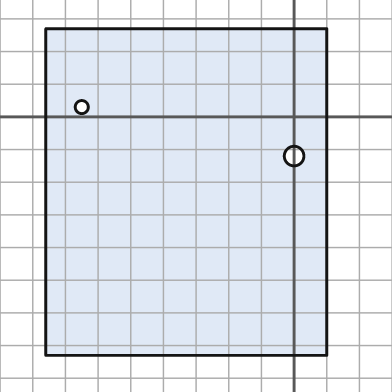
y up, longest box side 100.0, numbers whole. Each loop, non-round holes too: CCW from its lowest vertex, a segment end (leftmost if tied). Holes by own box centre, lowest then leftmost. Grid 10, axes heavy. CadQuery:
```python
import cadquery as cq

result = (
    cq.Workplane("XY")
    .moveTo(-76.0, -73.0)
    .lineTo(10.0, -73.0)
    .lineTo(10.0, 27.0)
    .lineTo(-76.0, 27.0)
    .close()
    .moveTo(0.0, -12.0)
    .circle(3.0)
    .moveTo(-65.0, 3.0)
    .circle(2.0)
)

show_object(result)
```